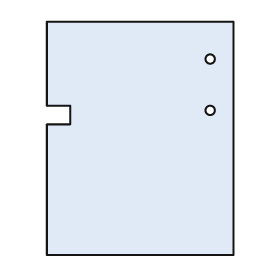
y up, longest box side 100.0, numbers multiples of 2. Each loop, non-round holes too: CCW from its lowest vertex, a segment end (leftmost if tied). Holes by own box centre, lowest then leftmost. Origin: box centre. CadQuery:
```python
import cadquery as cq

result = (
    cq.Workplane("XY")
    .moveTo(-40.0, -50.0)
    .lineTo(40.0, -50.0)
    .lineTo(40.0, 50.0)
    .lineTo(-40.0, 50.0)
    .lineTo(-40.0, 14.0)
    .lineTo(-30.0, 14.0)
    .lineTo(-30.0, 6.0)
    .lineTo(-40.0, 6.0)
    .close()
    .moveTo(30.0, 12.0)
    .circle(2.0)
    .moveTo(30.0, 34.0)
    .circle(2.0)
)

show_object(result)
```